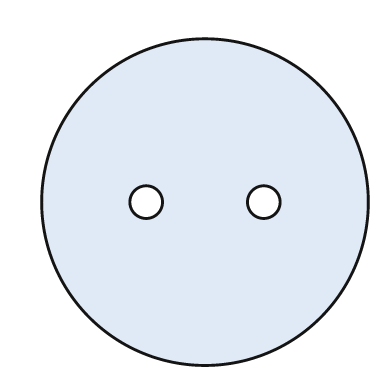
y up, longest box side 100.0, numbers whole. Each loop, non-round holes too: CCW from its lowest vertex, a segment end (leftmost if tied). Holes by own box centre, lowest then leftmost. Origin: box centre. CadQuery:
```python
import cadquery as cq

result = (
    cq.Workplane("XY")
    .moveTo(0.0, 0.0)
    .circle(50.0)
    .moveTo(-18.0, 0.0)
    .circle(5.0)
    .moveTo(18.0, 0.0)
    .circle(5.0)
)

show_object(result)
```